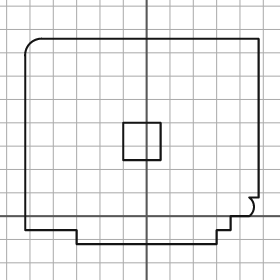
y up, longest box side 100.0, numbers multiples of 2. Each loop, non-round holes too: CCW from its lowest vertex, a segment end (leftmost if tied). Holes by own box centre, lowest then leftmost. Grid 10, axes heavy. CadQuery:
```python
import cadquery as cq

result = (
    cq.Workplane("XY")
    .moveTo(-30.0, -12.0)
    .lineTo(30.0, -12.0)
    .lineTo(30.0, -6.0)
    .lineTo(36.0, -6.0)
    .lineTo(36.0, 0.0)
    .lineTo(44.0, 0.0)
    .threePointArc((46.0, 4.0), (44.0, 8.0))
    .lineTo(48.0, 8.0)
    .lineTo(48.0, 76.0)
    .lineTo(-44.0, 76.0)
    .threePointArc((-50.0, 74.0), (-52.0, 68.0))
    .lineTo(-52.0, -6.0)
    .lineTo(-30.0, -6.0)
    .close()
    .moveTo(-10.0, 24.0)
    .lineTo(6.0, 24.0)
    .lineTo(6.0, 40.0)
    .lineTo(-10.0, 40.0)
    .close()
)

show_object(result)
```